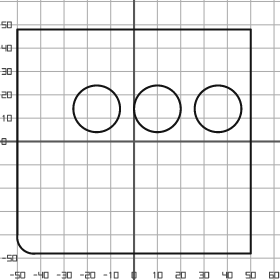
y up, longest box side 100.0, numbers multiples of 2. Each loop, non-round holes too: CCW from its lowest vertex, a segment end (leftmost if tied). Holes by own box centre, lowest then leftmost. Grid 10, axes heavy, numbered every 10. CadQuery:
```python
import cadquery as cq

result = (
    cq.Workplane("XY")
    .moveTo(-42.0, -48.0)
    .lineTo(50.0, -48.0)
    .lineTo(50.0, 48.0)
    .lineTo(-50.0, 48.0)
    .lineTo(-50.0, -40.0)
    .threePointArc((-48.0, -46.0), (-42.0, -48.0))
    .close()
    .moveTo(-16.0, 14.0)
    .circle(10.0)
    .moveTo(10.0, 14.0)
    .circle(10.0)
    .moveTo(36.0, 14.0)
    .circle(10.0)
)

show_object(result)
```